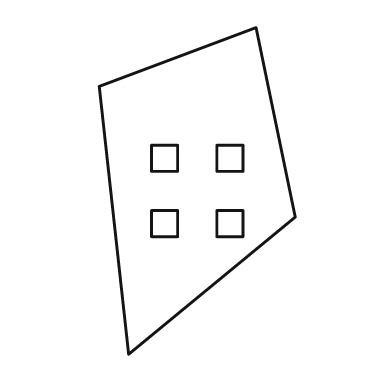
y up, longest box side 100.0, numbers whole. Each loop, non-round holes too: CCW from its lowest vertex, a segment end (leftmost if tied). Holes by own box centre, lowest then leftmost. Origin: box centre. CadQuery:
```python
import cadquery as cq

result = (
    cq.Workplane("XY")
    .moveTo(-21.0, -50.0)
    .lineTo(30.0, -8.0)
    .lineTo(18.0, 50.0)
    .lineTo(-30.0, 32.0)
    .close()
    .moveTo(-14.0, -14.0)
    .lineTo(-6.0, -14.0)
    .lineTo(-6.0, -6.0)
    .lineTo(-14.0, -6.0)
    .close()
    .moveTo(6.0, -14.0)
    .lineTo(14.0, -14.0)
    .lineTo(14.0, -6.0)
    .lineTo(6.0, -6.0)
    .close()
    .moveTo(-14.0, 6.0)
    .lineTo(-6.0, 6.0)
    .lineTo(-6.0, 14.0)
    .lineTo(-14.0, 14.0)
    .close()
    .moveTo(6.0, 6.0)
    .lineTo(14.0, 6.0)
    .lineTo(14.0, 14.0)
    .lineTo(6.0, 14.0)
    .close()
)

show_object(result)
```